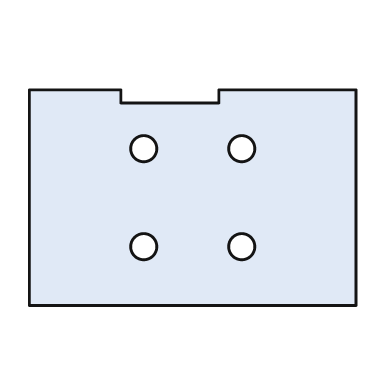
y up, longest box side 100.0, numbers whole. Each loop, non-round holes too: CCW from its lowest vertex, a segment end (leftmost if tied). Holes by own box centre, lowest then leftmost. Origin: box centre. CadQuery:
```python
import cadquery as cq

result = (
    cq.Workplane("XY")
    .moveTo(-50.0, -33.0)
    .lineTo(50.0, -33.0)
    .lineTo(50.0, 33.0)
    .lineTo(8.0, 33.0)
    .lineTo(8.0, 29.0)
    .lineTo(-22.0, 29.0)
    .lineTo(-22.0, 33.0)
    .lineTo(-50.0, 33.0)
    .close()
    .moveTo(-15.0, -15.0)
    .circle(4.0)
    .moveTo(15.0, -15.0)
    .circle(4.0)
    .moveTo(-15.0, 15.0)
    .circle(4.0)
    .moveTo(15.0, 15.0)
    .circle(4.0)
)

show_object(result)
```